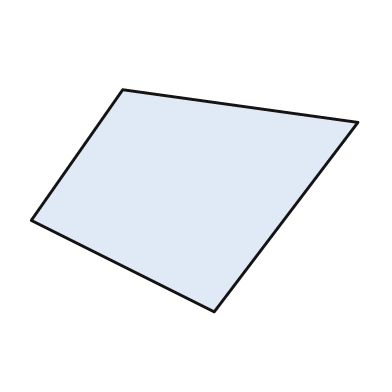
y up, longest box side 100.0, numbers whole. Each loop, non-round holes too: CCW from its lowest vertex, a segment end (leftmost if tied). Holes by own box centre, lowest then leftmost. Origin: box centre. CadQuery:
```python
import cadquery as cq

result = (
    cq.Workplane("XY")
    .moveTo(6.0, -34.0)
    .lineTo(50.0, 24.0)
    .lineTo(-22.0, 34.0)
    .lineTo(-50.0, -6.0)
    .close()
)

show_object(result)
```